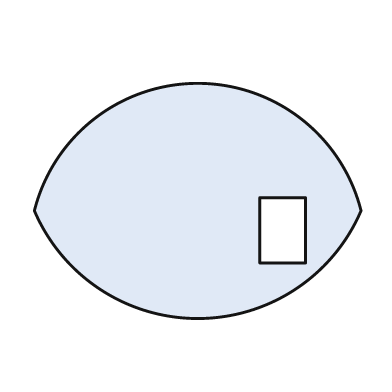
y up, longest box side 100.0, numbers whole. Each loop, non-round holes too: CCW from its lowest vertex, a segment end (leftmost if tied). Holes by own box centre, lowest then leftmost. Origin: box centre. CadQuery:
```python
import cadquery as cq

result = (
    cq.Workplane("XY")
    .moveTo(-50.0, -3.0)
    .threePointArc((0.0, -36.0), (50.0, -3.0))
    .threePointArc((0.0, 36.0), (-50.0, -3.0))
    .close()
    .moveTo(19.0, -19.0)
    .lineTo(33.0, -19.0)
    .lineTo(33.0, 1.0)
    .lineTo(19.0, 1.0)
    .close()
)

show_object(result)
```